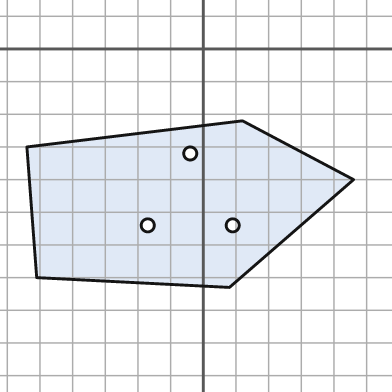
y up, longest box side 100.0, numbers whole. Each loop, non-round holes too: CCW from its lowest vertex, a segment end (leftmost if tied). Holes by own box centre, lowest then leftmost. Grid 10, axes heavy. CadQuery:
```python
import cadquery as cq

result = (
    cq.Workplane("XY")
    .moveTo(8.0, -73.0)
    .lineTo(46.0, -40.0)
    .lineTo(12.0, -22.0)
    .lineTo(-54.0, -30.0)
    .lineTo(-51.0, -70.0)
    .close()
    .moveTo(-17.0, -54.0)
    .circle(2.0)
    .moveTo(9.0, -54.0)
    .circle(2.0)
    .moveTo(-4.0, -32.0)
    .circle(2.0)
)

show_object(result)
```